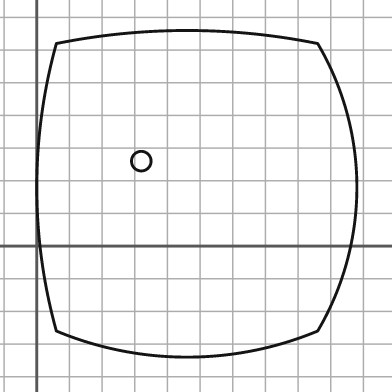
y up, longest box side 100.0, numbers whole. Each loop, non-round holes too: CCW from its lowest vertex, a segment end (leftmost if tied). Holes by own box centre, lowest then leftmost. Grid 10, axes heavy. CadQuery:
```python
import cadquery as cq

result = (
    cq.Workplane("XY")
    .moveTo(6.0, -26.0)
    .threePointArc((46.0, -34.0), (86.0, -26.0))
    .threePointArc((98.0, 18.0), (86.0, 62.0))
    .threePointArc((46.0, 66.0), (6.0, 62.0))
    .threePointArc((0.0, 18.0), (6.0, -26.0))
    .close()
    .moveTo(32.0, 26.0)
    .circle(3.0)
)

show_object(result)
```